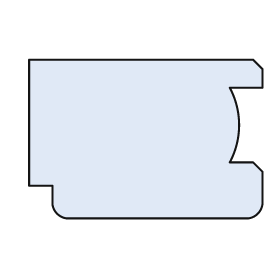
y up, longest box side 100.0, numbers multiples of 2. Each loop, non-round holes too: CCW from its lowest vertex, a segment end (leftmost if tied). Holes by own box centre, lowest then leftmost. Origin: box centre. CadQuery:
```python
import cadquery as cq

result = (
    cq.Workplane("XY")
    .moveTo(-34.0, -34.0)
    .lineTo(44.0, -34.0)
    .threePointArc((48.0, -32.0), (50.0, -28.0))
    .lineTo(50.0, -14.0)
    .lineTo(46.0, -10.0)
    .lineTo(36.0, -10.0)
    .threePointArc((40.0, 6.0), (36.0, 22.0))
    .lineTo(50.0, 22.0)
    .lineTo(50.0, 30.0)
    .lineTo(46.0, 34.0)
    .lineTo(-50.0, 34.0)
    .lineTo(-50.0, -20.0)
    .lineTo(-40.0, -20.0)
    .lineTo(-40.0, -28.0)
    .threePointArc((-38.0, -32.0), (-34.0, -34.0))
    .close()
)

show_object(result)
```